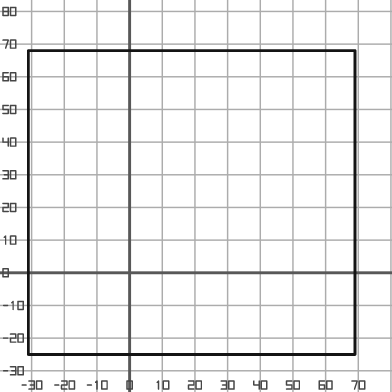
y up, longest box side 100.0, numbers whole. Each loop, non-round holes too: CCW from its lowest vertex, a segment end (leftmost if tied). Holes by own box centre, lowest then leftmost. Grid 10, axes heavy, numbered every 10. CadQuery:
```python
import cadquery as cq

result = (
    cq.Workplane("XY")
    .moveTo(-31.0, -25.0)
    .lineTo(69.0, -25.0)
    .lineTo(69.0, 68.0)
    .lineTo(-31.0, 68.0)
    .close()
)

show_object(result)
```